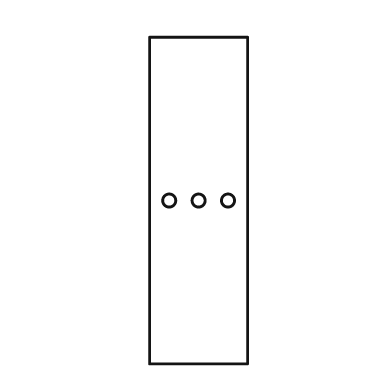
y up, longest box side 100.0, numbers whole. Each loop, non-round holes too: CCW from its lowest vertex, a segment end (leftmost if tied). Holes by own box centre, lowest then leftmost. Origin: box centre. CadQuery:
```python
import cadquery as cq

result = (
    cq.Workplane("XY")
    .moveTo(-15.0, -50.0)
    .lineTo(15.0, -50.0)
    .lineTo(15.0, 50.0)
    .lineTo(-15.0, 50.0)
    .close()
    .moveTo(-9.0, 0.0)
    .circle(2.0)
    .moveTo(0.0, 0.0)
    .circle(2.0)
    .moveTo(9.0, 0.0)
    .circle(2.0)
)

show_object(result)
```